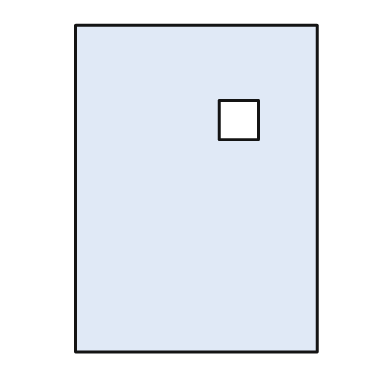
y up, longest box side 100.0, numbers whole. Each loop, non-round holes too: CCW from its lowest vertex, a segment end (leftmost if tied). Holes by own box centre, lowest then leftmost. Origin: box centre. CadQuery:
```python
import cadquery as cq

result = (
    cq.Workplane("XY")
    .moveTo(-37.0, -50.0)
    .lineTo(37.0, -50.0)
    .lineTo(37.0, 50.0)
    .lineTo(-37.0, 50.0)
    .close()
    .moveTo(7.0, 15.0)
    .lineTo(19.0, 15.0)
    .lineTo(19.0, 27.0)
    .lineTo(7.0, 27.0)
    .close()
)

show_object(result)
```